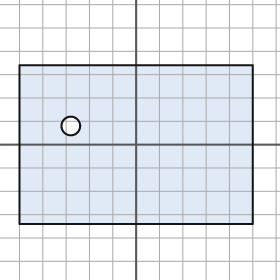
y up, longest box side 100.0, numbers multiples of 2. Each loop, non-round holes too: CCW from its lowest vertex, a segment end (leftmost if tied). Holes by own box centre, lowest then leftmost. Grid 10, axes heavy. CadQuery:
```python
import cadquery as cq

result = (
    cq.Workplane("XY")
    .moveTo(-50.0, -34.0)
    .lineTo(50.0, -34.0)
    .lineTo(50.0, 34.0)
    .lineTo(-50.0, 34.0)
    .close()
    .moveTo(-28.0, 8.0)
    .circle(4.0)
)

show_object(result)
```